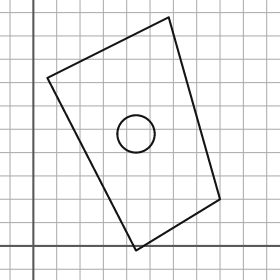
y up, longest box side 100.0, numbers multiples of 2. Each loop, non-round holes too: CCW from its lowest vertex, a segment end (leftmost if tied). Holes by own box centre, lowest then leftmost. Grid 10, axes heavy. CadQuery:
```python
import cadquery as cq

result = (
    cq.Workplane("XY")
    .moveTo(44.0, -2.0)
    .lineTo(80.0, 20.0)
    .lineTo(58.0, 98.0)
    .lineTo(6.0, 72.0)
    .close()
    .moveTo(44.0, 48.0)
    .circle(8.0)
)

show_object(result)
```